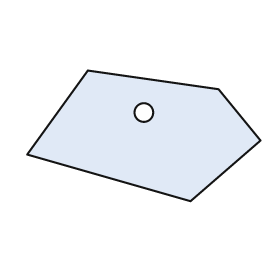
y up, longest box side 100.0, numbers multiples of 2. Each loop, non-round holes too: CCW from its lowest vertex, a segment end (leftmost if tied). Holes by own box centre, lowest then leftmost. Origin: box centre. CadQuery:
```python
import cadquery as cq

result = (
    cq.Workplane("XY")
    .moveTo(20.0, -28.0)
    .lineTo(50.0, -2.0)
    .lineTo(32.0, 20.0)
    .lineTo(-24.0, 28.0)
    .lineTo(-50.0, -8.0)
    .close()
    .moveTo(0.0, 10.0)
    .circle(4.0)
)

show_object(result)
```